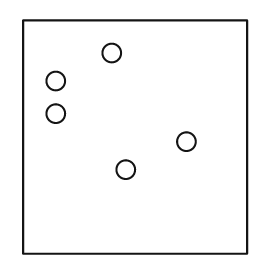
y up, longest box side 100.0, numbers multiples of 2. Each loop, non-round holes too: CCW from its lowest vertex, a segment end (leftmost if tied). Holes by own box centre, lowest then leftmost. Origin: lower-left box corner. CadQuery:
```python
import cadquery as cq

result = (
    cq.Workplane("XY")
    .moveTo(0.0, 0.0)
    .lineTo(96.0, 0.0)
    .lineTo(96.0, 100.0)
    .lineTo(0.0, 100.0)
    .close()
    .moveTo(44.0, 36.0)
    .circle(4.0)
    .moveTo(70.0, 48.0)
    .circle(4.0)
    .moveTo(14.0, 60.0)
    .circle(4.0)
    .moveTo(14.0, 74.0)
    .circle(4.0)
    .moveTo(38.0, 86.0)
    .circle(4.0)
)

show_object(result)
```